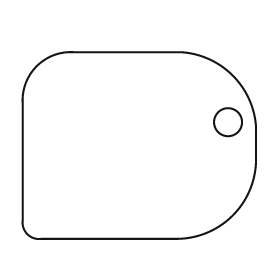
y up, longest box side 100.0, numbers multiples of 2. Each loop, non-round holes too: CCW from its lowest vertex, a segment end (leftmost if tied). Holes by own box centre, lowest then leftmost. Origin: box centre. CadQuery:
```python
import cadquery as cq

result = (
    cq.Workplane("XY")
    .moveTo(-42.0, -40.0)
    .lineTo(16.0, -40.0)
    .threePointArc((40.0, -30.0), (50.0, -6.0))
    .lineTo(50.0, 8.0)
    .threePointArc((40.0, 30.0), (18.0, 40.0))
    .lineTo(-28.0, 40.0)
    .threePointArc((-44.0, 34.0), (-50.0, 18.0))
    .lineTo(-50.0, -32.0)
    .threePointArc((-48.0, -38.0), (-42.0, -40.0))
    .close()
    .moveTo(38.0, 10.0)
    .circle(6.0)
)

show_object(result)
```